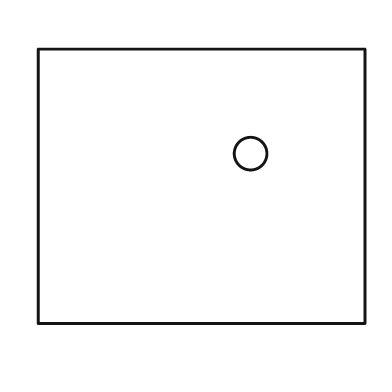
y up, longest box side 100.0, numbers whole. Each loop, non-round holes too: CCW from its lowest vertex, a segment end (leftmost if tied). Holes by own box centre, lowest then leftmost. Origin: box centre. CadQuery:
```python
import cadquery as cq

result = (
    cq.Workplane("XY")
    .moveTo(-50.0, -42.0)
    .lineTo(50.0, -42.0)
    .lineTo(50.0, 42.0)
    .lineTo(-50.0, 42.0)
    .close()
    .moveTo(15.0, 10.0)
    .circle(5.0)
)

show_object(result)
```